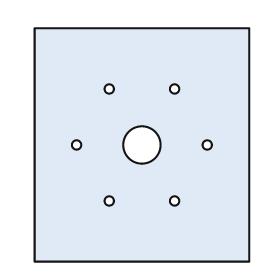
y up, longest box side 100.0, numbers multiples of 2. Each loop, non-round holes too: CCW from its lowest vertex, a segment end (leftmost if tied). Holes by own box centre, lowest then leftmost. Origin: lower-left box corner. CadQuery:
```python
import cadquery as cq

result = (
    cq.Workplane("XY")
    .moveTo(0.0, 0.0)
    .lineTo(92.0, 0.0)
    .lineTo(92.0, 100.0)
    .lineTo(0.0, 100.0)
    .close()
    .moveTo(32.0, 26.0)
    .circle(2.0)
    .moveTo(60.0, 26.0)
    .circle(2.0)
    .moveTo(18.0, 50.0)
    .circle(2.0)
    .moveTo(46.0, 50.0)
    .circle(8.0)
    .moveTo(74.0, 50.0)
    .circle(2.0)
    .moveTo(32.0, 74.0)
    .circle(2.0)
    .moveTo(60.0, 74.0)
    .circle(2.0)
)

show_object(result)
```